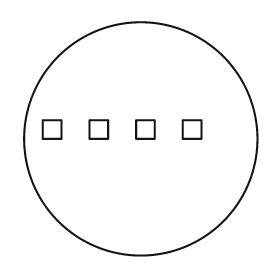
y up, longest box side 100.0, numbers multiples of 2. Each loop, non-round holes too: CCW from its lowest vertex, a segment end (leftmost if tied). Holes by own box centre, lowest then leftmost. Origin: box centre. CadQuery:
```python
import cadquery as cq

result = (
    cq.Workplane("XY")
    .moveTo(0.0, 0.0)
    .circle(50.0)
    .moveTo(-42.0, 0.0)
    .lineTo(-34.0, 0.0)
    .lineTo(-34.0, 8.0)
    .lineTo(-42.0, 8.0)
    .close()
    .moveTo(-22.0, 0.0)
    .lineTo(-14.0, 0.0)
    .lineTo(-14.0, 8.0)
    .lineTo(-22.0, 8.0)
    .close()
    .moveTo(-2.0, 0.0)
    .lineTo(6.0, 0.0)
    .lineTo(6.0, 8.0)
    .lineTo(-2.0, 8.0)
    .close()
    .moveTo(18.0, 0.0)
    .lineTo(26.0, 0.0)
    .lineTo(26.0, 8.0)
    .lineTo(18.0, 8.0)
    .close()
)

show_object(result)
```